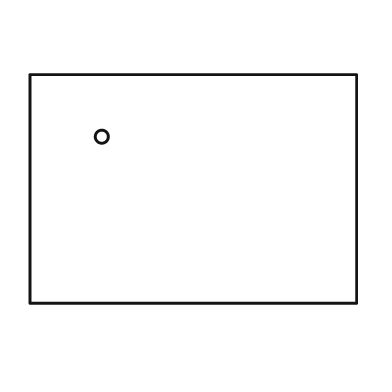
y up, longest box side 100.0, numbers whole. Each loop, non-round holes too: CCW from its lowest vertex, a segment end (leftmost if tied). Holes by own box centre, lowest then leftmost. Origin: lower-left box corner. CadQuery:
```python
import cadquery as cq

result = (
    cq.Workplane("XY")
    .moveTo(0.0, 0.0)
    .lineTo(100.0, 0.0)
    .lineTo(100.0, 70.0)
    .lineTo(0.0, 70.0)
    .close()
    .moveTo(22.0, 51.0)
    .circle(2.0)
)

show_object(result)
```